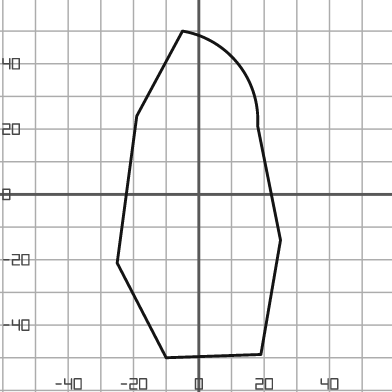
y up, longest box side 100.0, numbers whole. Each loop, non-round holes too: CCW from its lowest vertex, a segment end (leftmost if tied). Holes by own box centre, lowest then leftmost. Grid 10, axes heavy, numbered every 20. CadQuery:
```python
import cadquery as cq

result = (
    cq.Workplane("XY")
    .moveTo(-10.0, -50.0)
    .lineTo(19.0, -49.0)
    .lineTo(25.0, -14.0)
    .lineTo(18.0, 21.0)
    .threePointArc((12.0, 40.0), (-5.0, 50.0))
    .lineTo(-19.0, 24.0)
    .lineTo(-25.0, -21.0)
    .close()
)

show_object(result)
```